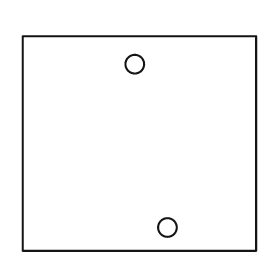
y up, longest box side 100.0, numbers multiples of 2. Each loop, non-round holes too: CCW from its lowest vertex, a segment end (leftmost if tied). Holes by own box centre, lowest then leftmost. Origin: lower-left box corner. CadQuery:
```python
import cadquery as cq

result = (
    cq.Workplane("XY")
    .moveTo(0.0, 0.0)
    .lineTo(100.0, 0.0)
    .lineTo(100.0, 92.0)
    .lineTo(0.0, 92.0)
    .close()
    .moveTo(62.0, 10.0)
    .circle(4.0)
    .moveTo(48.0, 80.0)
    .circle(4.0)
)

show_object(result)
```